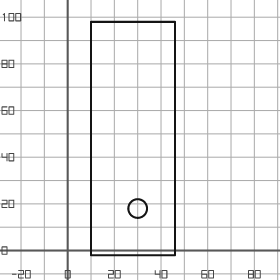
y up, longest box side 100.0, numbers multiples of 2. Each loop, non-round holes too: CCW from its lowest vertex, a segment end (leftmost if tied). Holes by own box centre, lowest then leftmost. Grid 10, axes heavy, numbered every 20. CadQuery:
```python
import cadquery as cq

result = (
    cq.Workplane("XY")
    .moveTo(10.0, -2.0)
    .lineTo(46.0, -2.0)
    .lineTo(46.0, 98.0)
    .lineTo(10.0, 98.0)
    .close()
    .moveTo(30.0, 18.0)
    .circle(4.0)
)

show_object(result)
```